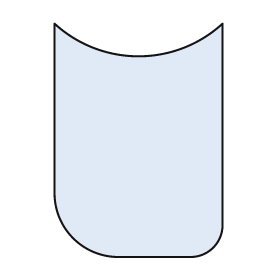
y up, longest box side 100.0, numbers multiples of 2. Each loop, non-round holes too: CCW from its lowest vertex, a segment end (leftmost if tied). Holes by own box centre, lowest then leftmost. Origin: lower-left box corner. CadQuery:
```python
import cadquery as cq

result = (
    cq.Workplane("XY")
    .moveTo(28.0, 0.0)
    .lineTo(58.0, 0.0)
    .threePointArc((68.0, 4.0), (72.0, 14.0))
    .lineTo(72.0, 100.0)
    .threePointArc((36.0, 86.0), (0.0, 100.0))
    .lineTo(0.0, 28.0)
    .threePointArc((8.0, 8.0), (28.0, 0.0))
    .close()
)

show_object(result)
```